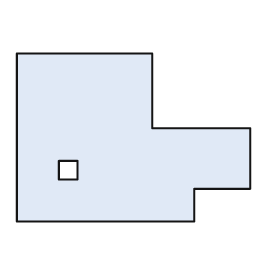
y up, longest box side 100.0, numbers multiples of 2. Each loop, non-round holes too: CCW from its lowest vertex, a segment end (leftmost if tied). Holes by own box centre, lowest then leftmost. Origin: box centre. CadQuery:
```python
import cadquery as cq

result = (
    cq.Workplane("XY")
    .moveTo(-50.0, -36.0)
    .lineTo(26.0, -36.0)
    .lineTo(26.0, -22.0)
    .lineTo(50.0, -22.0)
    .lineTo(50.0, 4.0)
    .lineTo(8.0, 4.0)
    .lineTo(8.0, 36.0)
    .lineTo(-50.0, 36.0)
    .close()
    .moveTo(-32.0, -18.0)
    .lineTo(-24.0, -18.0)
    .lineTo(-24.0, -10.0)
    .lineTo(-32.0, -10.0)
    .close()
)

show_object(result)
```